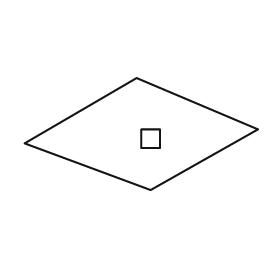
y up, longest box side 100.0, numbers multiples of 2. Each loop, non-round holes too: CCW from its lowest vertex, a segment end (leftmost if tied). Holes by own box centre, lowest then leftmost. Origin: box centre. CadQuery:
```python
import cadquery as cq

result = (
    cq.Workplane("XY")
    .moveTo(4.0, -24.0)
    .lineTo(50.0, 2.0)
    .lineTo(-2.0, 24.0)
    .lineTo(-50.0, -4.0)
    .close()
    .moveTo(0.0, -6.0)
    .lineTo(8.0, -6.0)
    .lineTo(8.0, 2.0)
    .lineTo(0.0, 2.0)
    .close()
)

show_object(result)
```